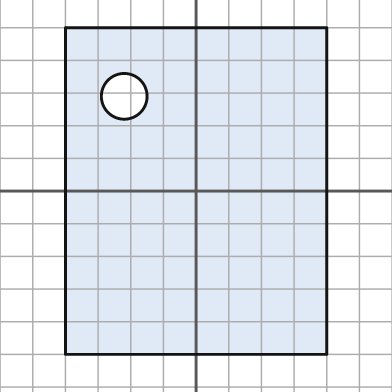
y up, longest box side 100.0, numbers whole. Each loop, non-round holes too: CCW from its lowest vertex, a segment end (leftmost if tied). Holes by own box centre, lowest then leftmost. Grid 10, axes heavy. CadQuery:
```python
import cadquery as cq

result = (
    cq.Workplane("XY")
    .moveTo(-40.0, -50.0)
    .lineTo(40.0, -50.0)
    .lineTo(40.0, 50.0)
    .lineTo(-40.0, 50.0)
    .close()
    .moveTo(-22.0, 29.0)
    .circle(7.0)
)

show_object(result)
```